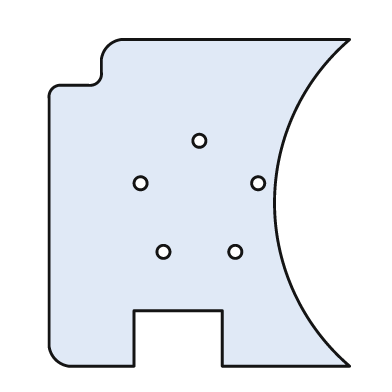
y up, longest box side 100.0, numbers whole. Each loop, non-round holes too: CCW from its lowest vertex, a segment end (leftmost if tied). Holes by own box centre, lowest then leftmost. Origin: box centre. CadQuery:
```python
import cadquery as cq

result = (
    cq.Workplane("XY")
    .moveTo(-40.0, -50.0)
    .lineTo(-20.0, -50.0)
    .lineTo(-20.0, -33.0)
    .lineTo(7.0, -33.0)
    .lineTo(7.0, -50.0)
    .lineTo(46.0, -50.0)
    .threePointArc((23.0, 0.0), (46.0, 50.0))
    .lineTo(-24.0, 50.0)
    .threePointArc((-28.0, 48.0), (-30.0, 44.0))
    .lineTo(-30.0, 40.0)
    .threePointArc((-31.0, 37.0), (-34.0, 36.0))
    .lineTo(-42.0, 36.0)
    .threePointArc((-45.0, 35.0), (-46.0, 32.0))
    .lineTo(-46.0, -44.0)
    .threePointArc((-44.0, -48.0), (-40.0, -50.0))
    .close()
    .moveTo(-11.0, -15.0)
    .circle(2.0)
    .moveTo(11.0, -15.0)
    .circle(2.0)
    .moveTo(-18.0, 6.0)
    .circle(2.0)
    .moveTo(18.0, 6.0)
    .circle(2.0)
    .moveTo(0.0, 19.0)
    .circle(2.0)
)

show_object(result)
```